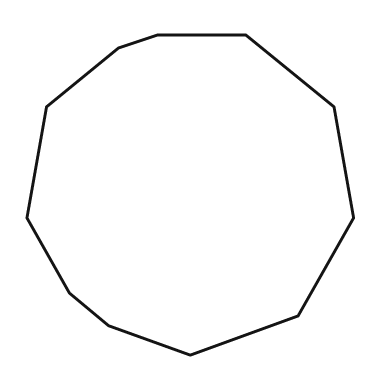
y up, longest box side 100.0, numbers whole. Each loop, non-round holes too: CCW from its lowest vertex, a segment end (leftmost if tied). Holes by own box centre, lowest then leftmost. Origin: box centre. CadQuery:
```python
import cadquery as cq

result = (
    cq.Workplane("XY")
    .moveTo(0.0, -49.0)
    .lineTo(33.0, -37.0)
    .lineTo(50.0, -7.0)
    .lineTo(44.0, 27.0)
    .lineTo(17.0, 49.0)
    .lineTo(-10.0, 49.0)
    .lineTo(-22.0, 45.0)
    .lineTo(-44.0, 27.0)
    .lineTo(-50.0, -7.0)
    .lineTo(-37.0, -30.0)
    .lineTo(-25.0, -40.0)
    .close()
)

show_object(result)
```